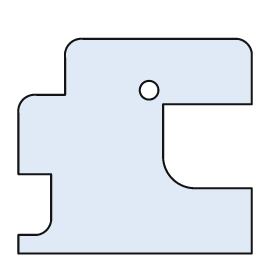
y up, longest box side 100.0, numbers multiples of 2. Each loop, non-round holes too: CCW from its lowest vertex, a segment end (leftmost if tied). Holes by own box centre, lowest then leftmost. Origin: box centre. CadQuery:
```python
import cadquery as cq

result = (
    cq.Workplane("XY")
    .moveTo(-50.0, -46.0)
    .lineTo(50.0, -46.0)
    .lineTo(50.0, -18.0)
    .lineTo(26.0, -18.0)
    .threePointArc((16.0, -14.0), (12.0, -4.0))
    .lineTo(12.0, 18.0)
    .lineTo(50.0, 18.0)
    .lineTo(50.0, 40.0)
    .threePointArc((48.0, 44.0), (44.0, 46.0))
    .lineTo(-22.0, 46.0)
    .threePointArc((-28.0, 44.0), (-30.0, 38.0))
    .lineTo(-30.0, 22.0)
    .lineTo(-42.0, 22.0)
    .threePointArc((-48.0, 20.0), (-50.0, 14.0))
    .lineTo(-50.0, -12.0)
    .lineTo(-36.0, -12.0)
    .lineTo(-36.0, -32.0)
    .threePointArc((-38.0, -36.0), (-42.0, -38.0))
    .lineTo(-50.0, -38.0)
    .close()
    .moveTo(6.0, 24.0)
    .circle(4.0)
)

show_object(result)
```